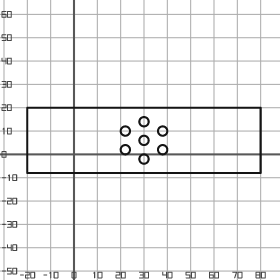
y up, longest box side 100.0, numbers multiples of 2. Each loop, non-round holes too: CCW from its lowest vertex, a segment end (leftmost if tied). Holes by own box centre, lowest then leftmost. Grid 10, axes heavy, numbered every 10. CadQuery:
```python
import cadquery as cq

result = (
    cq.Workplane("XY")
    .moveTo(-20.0, -8.0)
    .lineTo(80.0, -8.0)
    .lineTo(80.0, 20.0)
    .lineTo(-20.0, 20.0)
    .close()
    .moveTo(30.0, -2.0)
    .circle(2.0)
    .moveTo(22.0, 2.0)
    .circle(2.0)
    .moveTo(38.0, 2.0)
    .circle(2.0)
    .moveTo(30.0, 6.0)
    .circle(2.0)
    .moveTo(22.0, 10.0)
    .circle(2.0)
    .moveTo(38.0, 10.0)
    .circle(2.0)
    .moveTo(30.0, 14.0)
    .circle(2.0)
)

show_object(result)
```